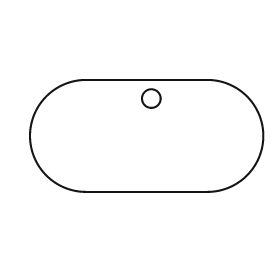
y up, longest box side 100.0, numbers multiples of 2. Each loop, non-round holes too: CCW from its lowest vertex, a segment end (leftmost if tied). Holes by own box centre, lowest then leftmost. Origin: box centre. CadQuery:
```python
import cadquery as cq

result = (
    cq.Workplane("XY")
    .moveTo(-26.0, -24.0)
    .lineTo(26.0, -24.0)
    .threePointArc((50.0, 0.0), (26.0, 24.0))
    .lineTo(-26.0, 24.0)
    .threePointArc((-50.0, 0.0), (-26.0, -24.0))
    .close()
    .moveTo(2.0, 16.0)
    .circle(4.0)
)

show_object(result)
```